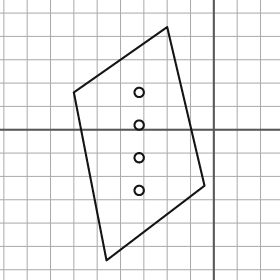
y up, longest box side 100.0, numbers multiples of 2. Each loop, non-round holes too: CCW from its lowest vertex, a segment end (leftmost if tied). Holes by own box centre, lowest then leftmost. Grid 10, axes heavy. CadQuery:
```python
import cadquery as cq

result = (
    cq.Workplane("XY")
    .moveTo(-46.0, -56.0)
    .lineTo(-4.0, -24.0)
    .lineTo(-20.0, 44.0)
    .lineTo(-60.0, 16.0)
    .close()
    .moveTo(-32.0, -26.0)
    .circle(2.0)
    .moveTo(-32.0, -12.0)
    .circle(2.0)
    .moveTo(-32.0, 2.0)
    .circle(2.0)
    .moveTo(-32.0, 16.0)
    .circle(2.0)
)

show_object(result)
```